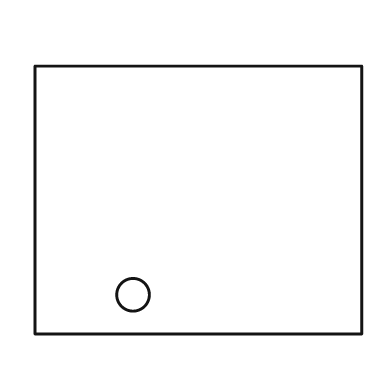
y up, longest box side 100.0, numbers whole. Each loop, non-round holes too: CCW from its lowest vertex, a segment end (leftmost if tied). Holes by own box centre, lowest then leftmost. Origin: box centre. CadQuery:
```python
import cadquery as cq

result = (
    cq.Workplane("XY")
    .moveTo(-50.0, -41.0)
    .lineTo(50.0, -41.0)
    .lineTo(50.0, 41.0)
    .lineTo(-50.0, 41.0)
    .close()
    .moveTo(-20.0, -29.0)
    .circle(5.0)
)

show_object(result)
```